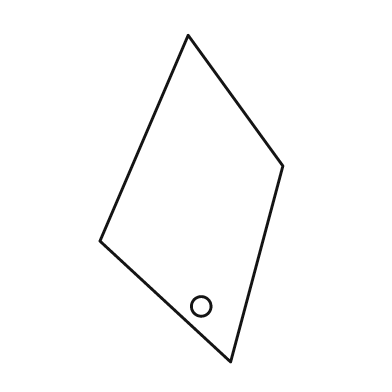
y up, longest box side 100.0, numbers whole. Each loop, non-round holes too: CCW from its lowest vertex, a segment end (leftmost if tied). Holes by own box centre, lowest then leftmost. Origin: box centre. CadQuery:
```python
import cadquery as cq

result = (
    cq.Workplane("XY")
    .moveTo(12.0, -50.0)
    .lineTo(28.0, 10.0)
    .lineTo(-1.0, 50.0)
    .lineTo(-28.0, -13.0)
    .close()
    .moveTo(3.0, -33.0)
    .circle(3.0)
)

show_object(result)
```